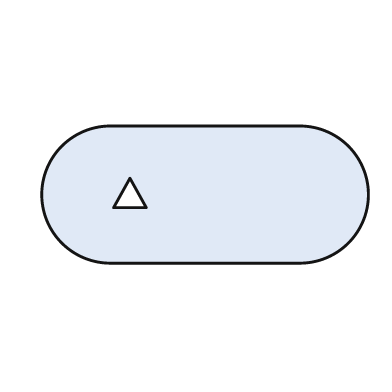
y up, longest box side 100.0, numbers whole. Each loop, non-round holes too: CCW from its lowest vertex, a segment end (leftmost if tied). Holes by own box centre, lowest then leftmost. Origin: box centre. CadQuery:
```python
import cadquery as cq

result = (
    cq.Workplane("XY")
    .moveTo(-29.0, -21.0)
    .lineTo(29.0, -21.0)
    .threePointArc((50.0, 0.0), (29.0, 21.0))
    .lineTo(-29.0, 21.0)
    .threePointArc((-50.0, 0.0), (-29.0, -21.0))
    .close()
    .moveTo(-28.0, -4.0)
    .lineTo(-18.0, -4.0)
    .lineTo(-23.0, 5.0)
    .close()
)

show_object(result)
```